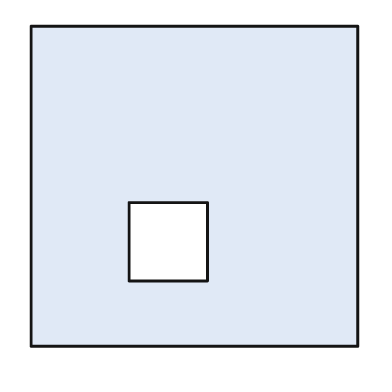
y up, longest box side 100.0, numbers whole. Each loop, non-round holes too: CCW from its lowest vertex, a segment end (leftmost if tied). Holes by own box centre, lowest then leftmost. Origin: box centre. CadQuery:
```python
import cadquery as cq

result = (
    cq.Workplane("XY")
    .moveTo(-50.0, -49.0)
    .lineTo(50.0, -49.0)
    .lineTo(50.0, 49.0)
    .lineTo(-50.0, 49.0)
    .close()
    .moveTo(-20.0, -29.0)
    .lineTo(4.0, -29.0)
    .lineTo(4.0, -5.0)
    .lineTo(-20.0, -5.0)
    .close()
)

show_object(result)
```